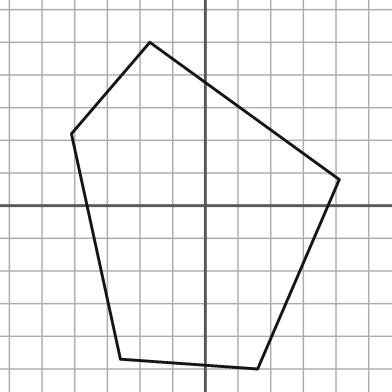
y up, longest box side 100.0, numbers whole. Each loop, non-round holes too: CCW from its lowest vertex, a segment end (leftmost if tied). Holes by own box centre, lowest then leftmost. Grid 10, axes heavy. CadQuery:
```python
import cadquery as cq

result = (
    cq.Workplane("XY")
    .moveTo(16.0, -50.0)
    .lineTo(41.0, 8.0)
    .lineTo(-17.0, 50.0)
    .lineTo(-41.0, 22.0)
    .lineTo(-26.0, -47.0)
    .close()
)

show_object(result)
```